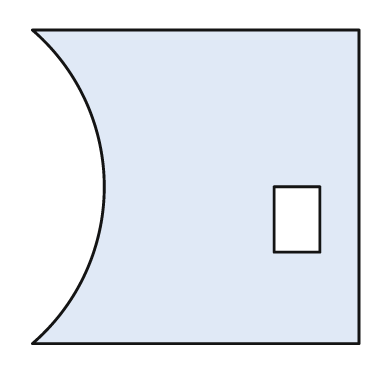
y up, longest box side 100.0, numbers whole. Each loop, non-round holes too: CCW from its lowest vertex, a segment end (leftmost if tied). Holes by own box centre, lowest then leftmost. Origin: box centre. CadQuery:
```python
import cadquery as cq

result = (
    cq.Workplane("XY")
    .moveTo(-50.0, -48.0)
    .lineTo(50.0, -48.0)
    .lineTo(50.0, 48.0)
    .lineTo(-50.0, 48.0)
    .threePointArc((-28.0, 0.0), (-50.0, -48.0))
    .close()
    .moveTo(24.0, -20.0)
    .lineTo(38.0, -20.0)
    .lineTo(38.0, 0.0)
    .lineTo(24.0, 0.0)
    .close()
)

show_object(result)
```